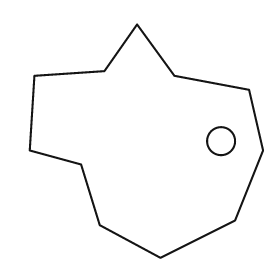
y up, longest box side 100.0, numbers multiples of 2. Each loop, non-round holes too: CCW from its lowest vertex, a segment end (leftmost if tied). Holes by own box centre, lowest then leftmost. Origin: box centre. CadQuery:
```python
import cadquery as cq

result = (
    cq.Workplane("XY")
    .moveTo(6.0, -50.0)
    .lineTo(38.0, -34.0)
    .lineTo(50.0, -4.0)
    .lineTo(44.0, 22.0)
    .lineTo(12.0, 28.0)
    .lineTo(-4.0, 50.0)
    .lineTo(-18.0, 30.0)
    .lineTo(-48.0, 28.0)
    .lineTo(-50.0, -4.0)
    .lineTo(-28.0, -10.0)
    .lineTo(-20.0, -36.0)
    .close()
    .moveTo(32.0, 0.0)
    .circle(6.0)
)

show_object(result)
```